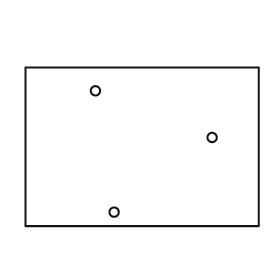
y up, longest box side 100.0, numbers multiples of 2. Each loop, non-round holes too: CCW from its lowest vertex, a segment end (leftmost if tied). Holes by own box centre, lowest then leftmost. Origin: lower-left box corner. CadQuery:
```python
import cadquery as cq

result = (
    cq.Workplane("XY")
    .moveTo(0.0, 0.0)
    .lineTo(100.0, 0.0)
    .lineTo(100.0, 68.0)
    .lineTo(0.0, 68.0)
    .close()
    .moveTo(38.0, 6.0)
    .circle(2.0)
    .moveTo(80.0, 38.0)
    .circle(2.0)
    .moveTo(30.0, 58.0)
    .circle(2.0)
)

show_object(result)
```